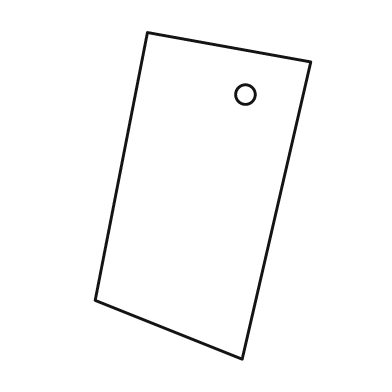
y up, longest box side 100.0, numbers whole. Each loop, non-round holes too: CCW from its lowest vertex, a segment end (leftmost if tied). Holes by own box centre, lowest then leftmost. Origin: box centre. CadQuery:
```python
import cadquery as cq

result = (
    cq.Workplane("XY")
    .moveTo(12.0, -50.0)
    .lineTo(33.0, 41.0)
    .lineTo(-17.0, 50.0)
    .lineTo(-33.0, -32.0)
    .close()
    .moveTo(13.0, 31.0)
    .circle(3.0)
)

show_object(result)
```